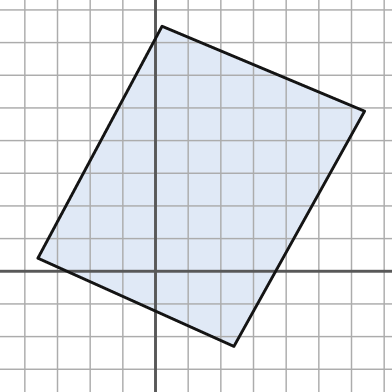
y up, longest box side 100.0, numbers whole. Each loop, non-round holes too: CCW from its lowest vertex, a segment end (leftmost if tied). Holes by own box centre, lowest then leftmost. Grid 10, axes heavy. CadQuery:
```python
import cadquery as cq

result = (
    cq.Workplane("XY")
    .moveTo(24.0, -23.0)
    .lineTo(64.0, 49.0)
    .lineTo(2.0, 75.0)
    .lineTo(-36.0, 4.0)
    .close()
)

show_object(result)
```